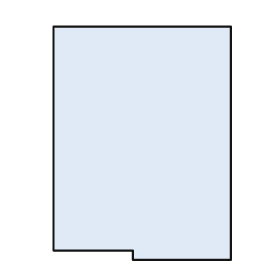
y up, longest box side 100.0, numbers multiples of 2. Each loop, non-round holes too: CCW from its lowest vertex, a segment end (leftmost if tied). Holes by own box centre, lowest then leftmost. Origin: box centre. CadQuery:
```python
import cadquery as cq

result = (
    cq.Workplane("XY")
    .moveTo(-4.0, -50.0)
    .lineTo(38.0, -50.0)
    .lineTo(38.0, 50.0)
    .lineTo(-38.0, 50.0)
    .lineTo(-38.0, -46.0)
    .lineTo(-4.0, -46.0)
    .close()
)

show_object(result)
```